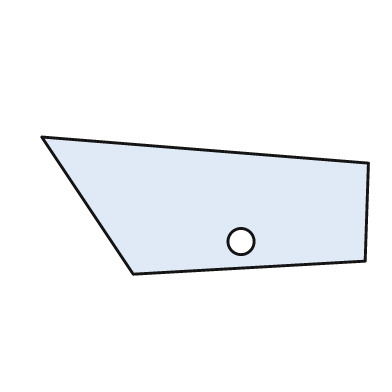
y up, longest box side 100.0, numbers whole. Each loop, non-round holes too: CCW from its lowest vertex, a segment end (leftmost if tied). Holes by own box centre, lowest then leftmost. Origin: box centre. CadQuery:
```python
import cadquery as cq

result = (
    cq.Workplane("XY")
    .moveTo(-22.0, -21.0)
    .lineTo(49.0, -17.0)
    .lineTo(50.0, 13.0)
    .lineTo(-50.0, 21.0)
    .close()
    .moveTo(11.0, -11.0)
    .circle(4.0)
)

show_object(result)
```